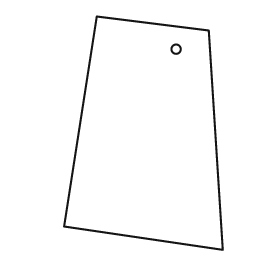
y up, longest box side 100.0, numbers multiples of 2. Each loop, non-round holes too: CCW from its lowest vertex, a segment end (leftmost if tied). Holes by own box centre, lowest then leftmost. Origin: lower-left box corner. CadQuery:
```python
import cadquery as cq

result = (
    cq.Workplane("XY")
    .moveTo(68.0, 0.0)
    .lineTo(62.0, 94.0)
    .lineTo(14.0, 100.0)
    .lineTo(0.0, 10.0)
    .close()
    .moveTo(48.0, 86.0)
    .circle(2.0)
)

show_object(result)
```